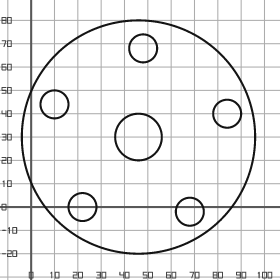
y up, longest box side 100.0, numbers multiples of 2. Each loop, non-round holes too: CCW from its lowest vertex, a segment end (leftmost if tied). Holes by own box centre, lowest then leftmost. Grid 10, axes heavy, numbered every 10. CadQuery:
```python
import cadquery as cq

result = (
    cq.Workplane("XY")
    .moveTo(46.0, 30.0)
    .circle(50.0)
    .moveTo(68.0, -2.0)
    .circle(6.0)
    .moveTo(22.0, 0.0)
    .circle(6.0)
    .moveTo(46.0, 30.0)
    .circle(10.0)
    .moveTo(84.0, 40.0)
    .circle(6.0)
    .moveTo(10.0, 44.0)
    .circle(6.0)
    .moveTo(48.0, 68.0)
    .circle(6.0)
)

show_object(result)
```